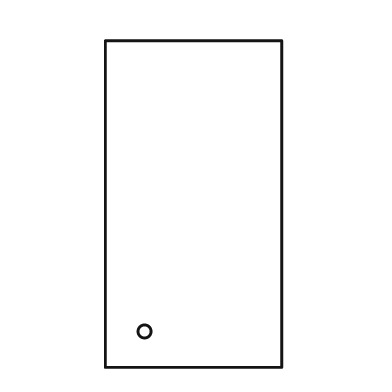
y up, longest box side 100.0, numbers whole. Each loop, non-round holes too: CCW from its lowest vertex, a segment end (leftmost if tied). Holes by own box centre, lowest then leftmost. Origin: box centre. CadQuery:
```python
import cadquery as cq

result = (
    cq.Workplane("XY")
    .moveTo(-27.0, -50.0)
    .lineTo(27.0, -50.0)
    .lineTo(27.0, 50.0)
    .lineTo(-27.0, 50.0)
    .close()
    .moveTo(-15.0, -39.0)
    .circle(2.0)
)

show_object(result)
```